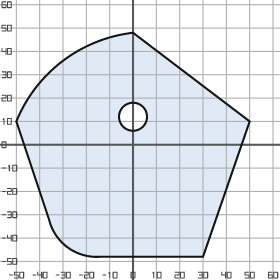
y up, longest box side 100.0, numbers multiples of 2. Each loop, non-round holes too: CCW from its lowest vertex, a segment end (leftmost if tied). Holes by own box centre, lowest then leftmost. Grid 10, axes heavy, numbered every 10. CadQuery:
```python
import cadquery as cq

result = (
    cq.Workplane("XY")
    .moveTo(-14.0, -48.0)
    .lineTo(30.0, -48.0)
    .lineTo(50.0, 10.0)
    .lineTo(0.0, 48.0)
    .threePointArc((-30.0, 36.0), (-50.0, 10.0))
    .lineTo(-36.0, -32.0)
    .threePointArc((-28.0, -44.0), (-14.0, -48.0))
    .close()
    .moveTo(0.0, 12.0)
    .circle(6.0)
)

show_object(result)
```